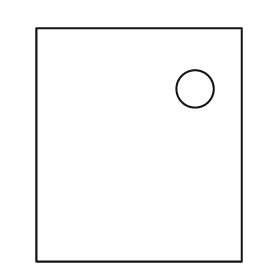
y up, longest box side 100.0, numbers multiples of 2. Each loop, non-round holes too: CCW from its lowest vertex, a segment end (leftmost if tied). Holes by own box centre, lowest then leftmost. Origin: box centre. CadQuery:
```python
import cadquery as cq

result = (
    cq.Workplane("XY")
    .moveTo(-44.0, -50.0)
    .lineTo(44.0, -50.0)
    .lineTo(44.0, 50.0)
    .lineTo(-44.0, 50.0)
    .close()
    .moveTo(24.0, 24.0)
    .circle(8.0)
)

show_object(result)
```